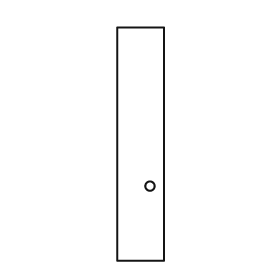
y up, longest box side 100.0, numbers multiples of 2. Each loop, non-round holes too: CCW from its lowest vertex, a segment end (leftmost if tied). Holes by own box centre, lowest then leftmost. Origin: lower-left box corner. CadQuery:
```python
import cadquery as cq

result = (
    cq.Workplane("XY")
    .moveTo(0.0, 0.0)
    .lineTo(20.0, 0.0)
    .lineTo(20.0, 100.0)
    .lineTo(0.0, 100.0)
    .close()
    .moveTo(14.0, 32.0)
    .circle(2.0)
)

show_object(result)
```